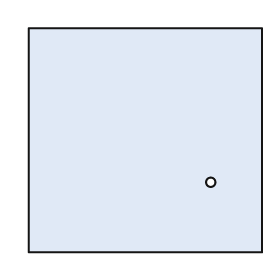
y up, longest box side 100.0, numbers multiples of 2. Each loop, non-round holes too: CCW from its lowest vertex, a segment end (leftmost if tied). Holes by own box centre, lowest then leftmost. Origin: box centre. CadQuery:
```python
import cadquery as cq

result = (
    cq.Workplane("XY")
    .moveTo(-50.0, -48.0)
    .lineTo(50.0, -48.0)
    .lineTo(50.0, 48.0)
    .lineTo(-50.0, 48.0)
    .close()
    .moveTo(28.0, -18.0)
    .circle(2.0)
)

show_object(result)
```